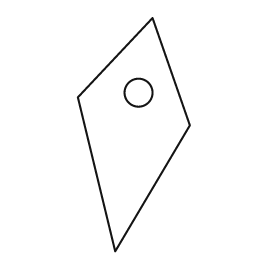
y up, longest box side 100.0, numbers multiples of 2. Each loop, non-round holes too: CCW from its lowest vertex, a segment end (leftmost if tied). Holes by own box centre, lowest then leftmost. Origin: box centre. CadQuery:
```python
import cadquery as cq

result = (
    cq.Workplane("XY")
    .moveTo(-8.0, -50.0)
    .lineTo(24.0, 4.0)
    .lineTo(8.0, 50.0)
    .lineTo(-24.0, 16.0)
    .close()
    .moveTo(2.0, 18.0)
    .circle(6.0)
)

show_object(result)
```